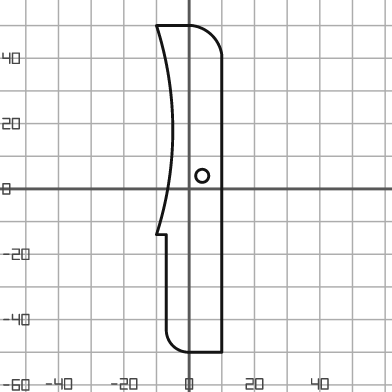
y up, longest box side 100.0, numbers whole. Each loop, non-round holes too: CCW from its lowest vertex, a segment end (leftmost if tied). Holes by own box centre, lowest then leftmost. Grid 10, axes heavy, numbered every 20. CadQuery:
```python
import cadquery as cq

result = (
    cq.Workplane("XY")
    .moveTo(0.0, -50.0)
    .lineTo(10.0, -50.0)
    .lineTo(10.0, 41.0)
    .threePointArc((7.0, 47.0), (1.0, 50.0))
    .lineTo(-10.0, 50.0)
    .threePointArc((-5.0, 18.0), (-10.0, -14.0))
    .lineTo(-7.0, -14.0)
    .lineTo(-7.0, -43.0)
    .threePointArc((-5.0, -48.0), (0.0, -50.0))
    .close()
    .moveTo(4.0, 4.0)
    .circle(2.0)
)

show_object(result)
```